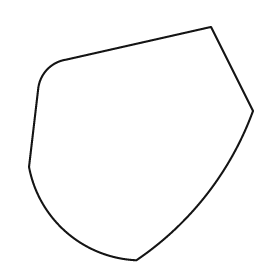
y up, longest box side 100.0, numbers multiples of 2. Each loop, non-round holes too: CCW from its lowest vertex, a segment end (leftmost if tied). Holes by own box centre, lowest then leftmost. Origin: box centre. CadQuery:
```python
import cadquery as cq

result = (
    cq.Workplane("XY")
    .moveTo(-2.0, -50.0)
    .threePointArc((28.0, -22.0), (48.0, 14.0))
    .lineTo(30.0, 50.0)
    .lineTo(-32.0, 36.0)
    .threePointArc((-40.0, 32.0), (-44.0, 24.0))
    .lineTo(-48.0, -10.0)
    .threePointArc((-32.0, -38.0), (-2.0, -50.0))
    .close()
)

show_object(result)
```